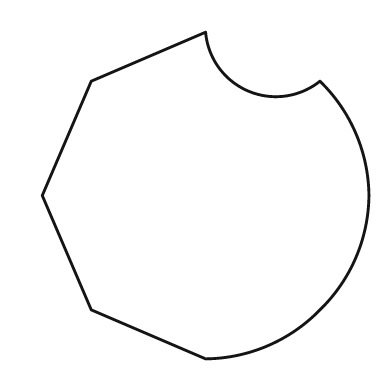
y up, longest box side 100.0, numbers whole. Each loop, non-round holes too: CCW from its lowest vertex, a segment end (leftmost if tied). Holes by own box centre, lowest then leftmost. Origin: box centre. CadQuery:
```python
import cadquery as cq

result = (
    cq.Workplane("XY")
    .moveTo(0.0, -50.0)
    .threePointArc((19.0, -46.0), (35.0, -35.0))
    .threePointArc((46.0, -19.0), (50.0, 0.0))
    .threePointArc((46.0, 19.0), (35.0, 35.0))
    .threePointArc((13.0, 32.0), (0.0, 50.0))
    .lineTo(-35.0, 35.0)
    .lineTo(-50.0, 0.0)
    .lineTo(-35.0, -35.0)
    .close()
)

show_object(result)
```